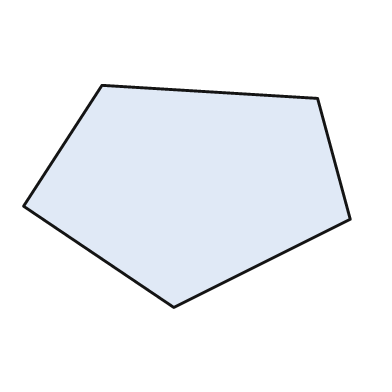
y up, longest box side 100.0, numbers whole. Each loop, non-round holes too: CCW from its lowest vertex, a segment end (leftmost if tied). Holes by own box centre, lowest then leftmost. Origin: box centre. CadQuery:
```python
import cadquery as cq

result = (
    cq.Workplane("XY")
    .moveTo(-4.0, -34.0)
    .lineTo(50.0, -7.0)
    .lineTo(40.0, 30.0)
    .lineTo(-26.0, 34.0)
    .lineTo(-50.0, -3.0)
    .close()
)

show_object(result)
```